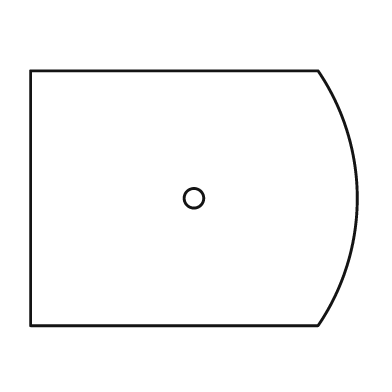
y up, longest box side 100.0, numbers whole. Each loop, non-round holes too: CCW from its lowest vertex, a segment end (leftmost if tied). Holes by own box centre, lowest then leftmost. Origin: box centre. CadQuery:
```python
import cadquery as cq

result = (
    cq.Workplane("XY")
    .moveTo(-50.0, -39.0)
    .lineTo(38.0, -39.0)
    .threePointArc((50.0, 0.0), (38.0, 39.0))
    .lineTo(-50.0, 39.0)
    .close()
    .moveTo(0.0, 0.0)
    .circle(3.0)
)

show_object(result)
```